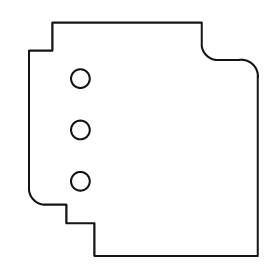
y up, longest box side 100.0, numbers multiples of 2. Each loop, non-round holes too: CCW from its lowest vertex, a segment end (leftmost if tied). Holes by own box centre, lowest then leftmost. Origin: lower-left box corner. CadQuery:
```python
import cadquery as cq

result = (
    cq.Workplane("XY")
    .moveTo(28.0, 0.0)
    .lineTo(98.0, 0.0)
    .lineTo(98.0, 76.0)
    .threePointArc((96.0, 82.0), (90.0, 84.0))
    .lineTo(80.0, 84.0)
    .threePointArc((76.0, 86.0), (74.0, 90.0))
    .lineTo(74.0, 100.0)
    .lineTo(10.0, 100.0)
    .lineTo(10.0, 88.0)
    .lineTo(0.0, 88.0)
    .lineTo(0.0, 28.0)
    .threePointArc((2.0, 24.0), (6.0, 22.0))
    .lineTo(16.0, 22.0)
    .lineTo(16.0, 14.0)
    .lineTo(28.0, 14.0)
    .close()
    .moveTo(22.0, 32.0)
    .circle(4.0)
    .moveTo(22.0, 54.0)
    .circle(4.0)
    .moveTo(22.0, 76.0)
    .circle(4.0)
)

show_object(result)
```